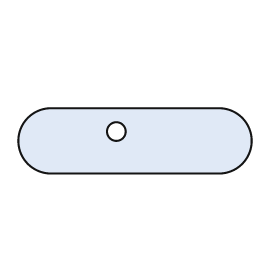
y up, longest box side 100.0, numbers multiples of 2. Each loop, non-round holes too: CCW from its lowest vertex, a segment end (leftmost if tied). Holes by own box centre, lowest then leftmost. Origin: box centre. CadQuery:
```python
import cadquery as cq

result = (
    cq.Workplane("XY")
    .moveTo(-36.0, -14.0)
    .lineTo(36.0, -14.0)
    .threePointArc((50.0, 0.0), (36.0, 14.0))
    .lineTo(-36.0, 14.0)
    .threePointArc((-50.0, 0.0), (-36.0, -14.0))
    .close()
    .moveTo(-8.0, 4.0)
    .circle(4.0)
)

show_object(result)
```